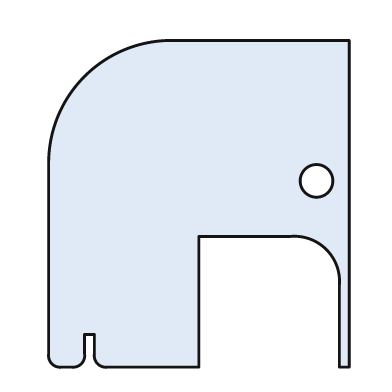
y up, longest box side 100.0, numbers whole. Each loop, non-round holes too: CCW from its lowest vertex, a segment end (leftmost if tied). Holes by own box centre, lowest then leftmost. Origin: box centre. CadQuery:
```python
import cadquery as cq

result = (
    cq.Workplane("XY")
    .moveTo(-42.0, -50.0)
    .lineTo(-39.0, -50.0)
    .threePointArc((-36.0, -49.0), (-35.0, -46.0))
    .lineTo(-35.0, -40.0)
    .lineTo(-32.0, -40.0)
    .lineTo(-32.0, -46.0)
    .threePointArc((-31.0, -49.0), (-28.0, -50.0))
    .lineTo(0.0, -50.0)
    .lineTo(0.0, -10.0)
    .lineTo(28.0, -10.0)
    .threePointArc((39.0, -14.0), (43.0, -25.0))
    .lineTo(43.0, -50.0)
    .lineTo(46.0, -50.0)
    .lineTo(46.0, 50.0)
    .lineTo(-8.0, 50.0)
    .threePointArc((-35.0, 39.0), (-46.0, 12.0))
    .lineTo(-46.0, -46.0)
    .threePointArc((-45.0, -49.0), (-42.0, -50.0))
    .close()
    .moveTo(36.0, 7.0)
    .circle(5.0)
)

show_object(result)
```